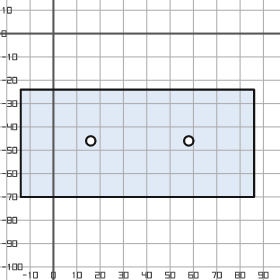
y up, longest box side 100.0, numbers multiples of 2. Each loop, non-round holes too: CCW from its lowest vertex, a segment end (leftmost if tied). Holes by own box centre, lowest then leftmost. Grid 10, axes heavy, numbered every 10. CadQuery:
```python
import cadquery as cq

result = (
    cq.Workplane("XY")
    .moveTo(-14.0, -70.0)
    .lineTo(86.0, -70.0)
    .lineTo(86.0, -24.0)
    .lineTo(-14.0, -24.0)
    .close()
    .moveTo(16.0, -46.0)
    .circle(2.0)
    .moveTo(58.0, -46.0)
    .circle(2.0)
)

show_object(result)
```